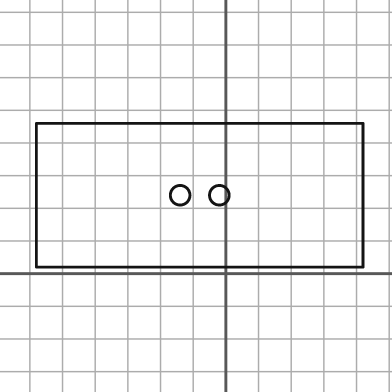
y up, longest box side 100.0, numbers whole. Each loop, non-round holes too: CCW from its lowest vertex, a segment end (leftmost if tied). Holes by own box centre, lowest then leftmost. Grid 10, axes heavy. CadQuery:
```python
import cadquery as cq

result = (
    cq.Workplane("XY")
    .moveTo(-58.0, 2.0)
    .lineTo(42.0, 2.0)
    .lineTo(42.0, 46.0)
    .lineTo(-58.0, 46.0)
    .close()
    .moveTo(-14.0, 24.0)
    .circle(3.0)
    .moveTo(-2.0, 24.0)
    .circle(3.0)
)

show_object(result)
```